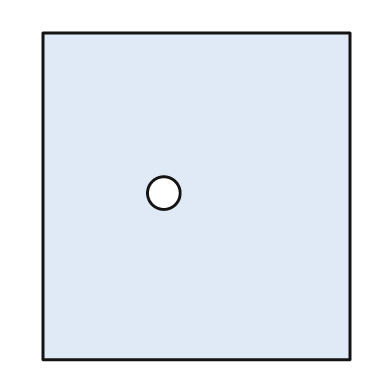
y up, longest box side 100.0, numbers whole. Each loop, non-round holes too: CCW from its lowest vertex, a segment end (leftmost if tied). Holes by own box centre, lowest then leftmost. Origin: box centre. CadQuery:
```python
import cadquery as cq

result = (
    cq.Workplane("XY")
    .moveTo(-47.0, -50.0)
    .lineTo(47.0, -50.0)
    .lineTo(47.0, 50.0)
    .lineTo(-47.0, 50.0)
    .close()
    .moveTo(-10.0, 1.0)
    .circle(5.0)
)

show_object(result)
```